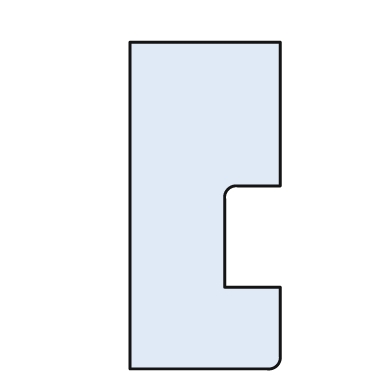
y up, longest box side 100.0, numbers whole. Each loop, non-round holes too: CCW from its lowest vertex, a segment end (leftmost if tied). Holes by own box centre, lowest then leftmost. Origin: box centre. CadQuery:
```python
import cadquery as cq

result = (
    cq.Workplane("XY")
    .moveTo(-23.0, -50.0)
    .lineTo(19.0, -50.0)
    .threePointArc((22.0, -49.0), (23.0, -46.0))
    .lineTo(23.0, -25.0)
    .lineTo(6.0, -25.0)
    .lineTo(6.0, 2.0)
    .threePointArc((7.0, 5.0), (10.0, 6.0))
    .lineTo(23.0, 6.0)
    .lineTo(23.0, 50.0)
    .lineTo(-23.0, 50.0)
    .close()
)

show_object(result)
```